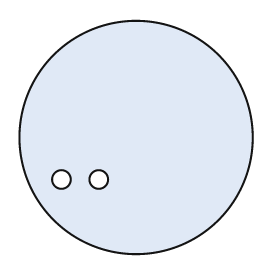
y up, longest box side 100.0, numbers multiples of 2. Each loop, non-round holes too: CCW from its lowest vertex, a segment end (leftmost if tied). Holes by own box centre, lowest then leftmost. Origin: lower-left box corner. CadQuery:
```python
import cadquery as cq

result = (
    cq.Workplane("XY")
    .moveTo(50.0, 50.0)
    .circle(50.0)
    .moveTo(18.0, 32.0)
    .circle(4.0)
    .moveTo(34.0, 32.0)
    .circle(4.0)
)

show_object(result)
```